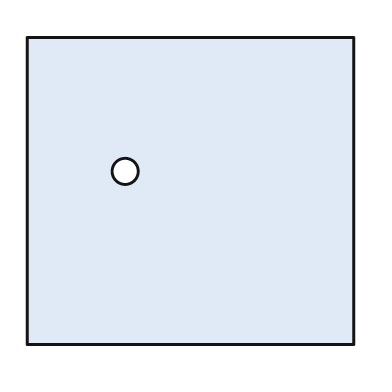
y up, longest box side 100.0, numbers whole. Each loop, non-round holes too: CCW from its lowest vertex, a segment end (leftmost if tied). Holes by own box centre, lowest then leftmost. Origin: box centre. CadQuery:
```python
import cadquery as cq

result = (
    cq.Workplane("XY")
    .moveTo(-50.0, -47.0)
    .lineTo(50.0, -47.0)
    .lineTo(50.0, 47.0)
    .lineTo(-50.0, 47.0)
    .close()
    .moveTo(-20.0, 6.0)
    .circle(4.0)
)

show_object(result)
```